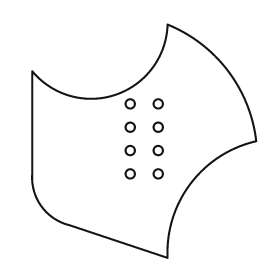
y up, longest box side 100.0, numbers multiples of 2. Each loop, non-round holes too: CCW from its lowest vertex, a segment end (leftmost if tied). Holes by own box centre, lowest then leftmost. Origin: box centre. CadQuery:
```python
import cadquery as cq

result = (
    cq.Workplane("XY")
    .moveTo(10.0, -50.0)
    .threePointArc((20.0, -18.0), (48.0, 0.0))
    .threePointArc((36.0, 30.0), (10.0, 50.0))
    .threePointArc((-12.0, 20.0), (-48.0, 30.0))
    .lineTo(-48.0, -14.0)
    .threePointArc((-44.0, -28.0), (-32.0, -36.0))
    .close()
    .moveTo(-6.0, -14.0)
    .circle(2.0)
    .moveTo(6.0, -14.0)
    .circle(2.0)
    .moveTo(-6.0, -4.0)
    .circle(2.0)
    .moveTo(6.0, -4.0)
    .circle(2.0)
    .moveTo(-6.0, 6.0)
    .circle(2.0)
    .moveTo(6.0, 6.0)
    .circle(2.0)
    .moveTo(-6.0, 16.0)
    .circle(2.0)
    .moveTo(6.0, 16.0)
    .circle(2.0)
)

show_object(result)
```